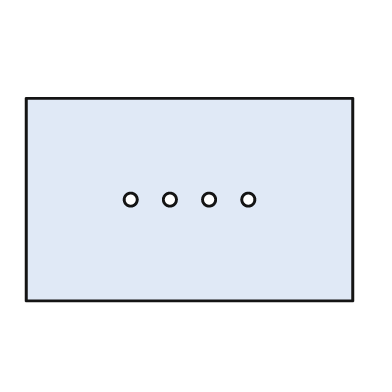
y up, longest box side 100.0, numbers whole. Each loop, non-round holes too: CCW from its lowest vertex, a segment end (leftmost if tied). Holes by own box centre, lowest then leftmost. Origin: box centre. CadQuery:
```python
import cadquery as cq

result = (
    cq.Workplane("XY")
    .moveTo(-50.0, -31.0)
    .lineTo(50.0, -31.0)
    .lineTo(50.0, 31.0)
    .lineTo(-50.0, 31.0)
    .close()
    .moveTo(-18.0, 0.0)
    .circle(2.0)
    .moveTo(-6.0, 0.0)
    .circle(2.0)
    .moveTo(6.0, 0.0)
    .circle(2.0)
    .moveTo(18.0, 0.0)
    .circle(2.0)
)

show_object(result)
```